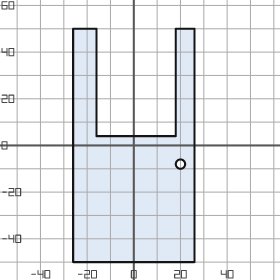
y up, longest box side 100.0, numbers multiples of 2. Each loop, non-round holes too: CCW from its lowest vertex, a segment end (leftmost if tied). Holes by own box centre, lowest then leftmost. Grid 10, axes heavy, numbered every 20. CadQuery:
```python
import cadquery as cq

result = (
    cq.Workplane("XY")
    .moveTo(-26.0, -50.0)
    .lineTo(26.0, -50.0)
    .lineTo(26.0, 50.0)
    .lineTo(18.0, 50.0)
    .lineTo(18.0, 4.0)
    .lineTo(-16.0, 4.0)
    .lineTo(-16.0, 50.0)
    .lineTo(-26.0, 50.0)
    .close()
    .moveTo(20.0, -8.0)
    .circle(2.0)
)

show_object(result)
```